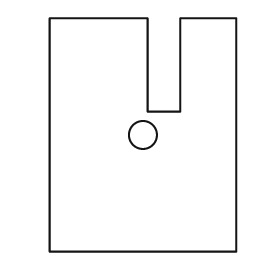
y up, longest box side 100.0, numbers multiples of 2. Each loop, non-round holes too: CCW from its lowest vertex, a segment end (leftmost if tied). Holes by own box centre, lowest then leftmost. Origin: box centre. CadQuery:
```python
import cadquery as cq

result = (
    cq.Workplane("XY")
    .moveTo(-40.0, -50.0)
    .lineTo(40.0, -50.0)
    .lineTo(40.0, 50.0)
    .lineTo(16.0, 50.0)
    .lineTo(16.0, 10.0)
    .lineTo(2.0, 10.0)
    .lineTo(2.0, 50.0)
    .lineTo(-40.0, 50.0)
    .close()
    .moveTo(0.0, 0.0)
    .circle(6.0)
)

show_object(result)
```